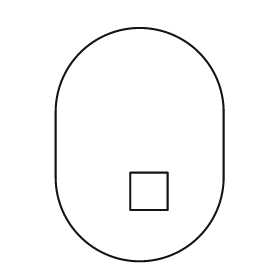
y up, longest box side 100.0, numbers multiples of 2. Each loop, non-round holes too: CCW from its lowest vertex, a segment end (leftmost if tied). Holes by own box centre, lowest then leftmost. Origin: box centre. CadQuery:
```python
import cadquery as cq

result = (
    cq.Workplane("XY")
    .moveTo(-36.0, -14.0)
    .threePointArc((0.0, -50.0), (36.0, -14.0))
    .lineTo(36.0, 14.0)
    .threePointArc((0.0, 50.0), (-36.0, 14.0))
    .close()
    .moveTo(-4.0, -28.0)
    .lineTo(12.0, -28.0)
    .lineTo(12.0, -12.0)
    .lineTo(-4.0, -12.0)
    .close()
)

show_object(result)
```